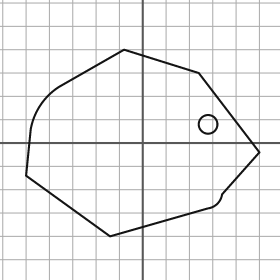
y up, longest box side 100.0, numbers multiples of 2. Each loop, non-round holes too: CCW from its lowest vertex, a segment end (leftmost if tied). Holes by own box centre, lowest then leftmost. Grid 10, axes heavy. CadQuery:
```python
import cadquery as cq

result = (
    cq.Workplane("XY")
    .moveTo(-14.0, -40.0)
    .lineTo(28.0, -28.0)
    .threePointArc((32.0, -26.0), (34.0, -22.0))
    .lineTo(50.0, -4.0)
    .lineTo(24.0, 30.0)
    .lineTo(-8.0, 40.0)
    .lineTo(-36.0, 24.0)
    .threePointArc((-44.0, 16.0), (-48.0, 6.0))
    .lineTo(-50.0, -14.0)
    .close()
    .moveTo(28.0, 8.0)
    .circle(4.0)
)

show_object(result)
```